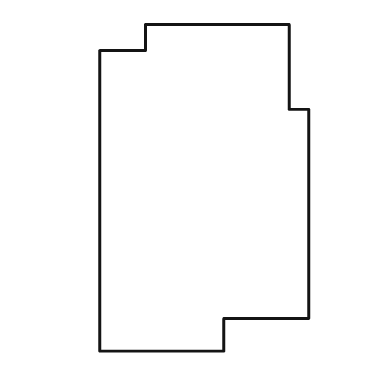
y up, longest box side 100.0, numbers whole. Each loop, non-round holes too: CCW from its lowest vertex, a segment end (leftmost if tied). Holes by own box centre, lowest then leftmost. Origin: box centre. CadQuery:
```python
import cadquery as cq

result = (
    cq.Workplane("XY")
    .moveTo(-32.0, -50.0)
    .lineTo(6.0, -50.0)
    .lineTo(6.0, -40.0)
    .lineTo(32.0, -40.0)
    .lineTo(32.0, 24.0)
    .lineTo(26.0, 24.0)
    .lineTo(26.0, 50.0)
    .lineTo(-18.0, 50.0)
    .lineTo(-18.0, 42.0)
    .lineTo(-32.0, 42.0)
    .close()
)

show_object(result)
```